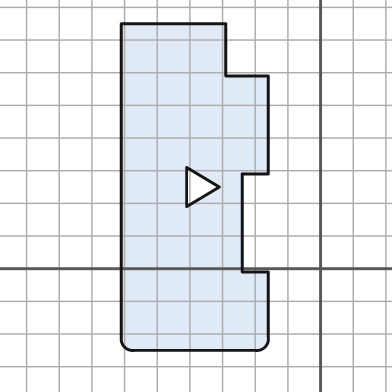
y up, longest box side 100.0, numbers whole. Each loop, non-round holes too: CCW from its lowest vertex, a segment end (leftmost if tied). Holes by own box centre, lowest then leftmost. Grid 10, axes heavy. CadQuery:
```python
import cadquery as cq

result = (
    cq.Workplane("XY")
    .moveTo(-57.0, -25.0)
    .lineTo(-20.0, -25.0)
    .threePointArc((-17.0, -24.0), (-16.0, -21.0))
    .lineTo(-16.0, -1.0)
    .lineTo(-24.0, -1.0)
    .lineTo(-24.0, 29.0)
    .lineTo(-16.0, 29.0)
    .lineTo(-16.0, 59.0)
    .lineTo(-29.0, 59.0)
    .lineTo(-29.0, 75.0)
    .lineTo(-61.0, 75.0)
    .lineTo(-61.0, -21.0)
    .threePointArc((-60.0, -24.0), (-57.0, -25.0))
    .close()
    .moveTo(-41.0, 19.0)
    .lineTo(-31.0, 25.0)
    .lineTo(-41.0, 31.0)
    .close()
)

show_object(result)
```